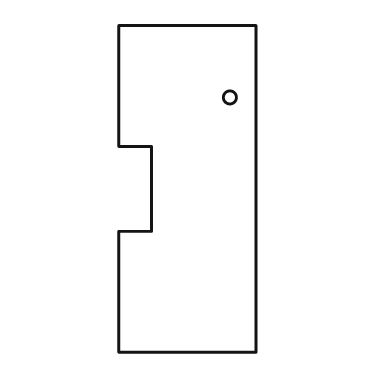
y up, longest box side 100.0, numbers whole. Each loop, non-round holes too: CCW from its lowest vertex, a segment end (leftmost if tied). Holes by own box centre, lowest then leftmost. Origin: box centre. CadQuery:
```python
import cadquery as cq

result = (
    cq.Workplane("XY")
    .moveTo(-21.0, -50.0)
    .lineTo(21.0, -50.0)
    .lineTo(21.0, 50.0)
    .lineTo(-21.0, 50.0)
    .lineTo(-21.0, 13.0)
    .lineTo(-11.0, 13.0)
    .lineTo(-11.0, -13.0)
    .lineTo(-21.0, -13.0)
    .close()
    .moveTo(13.0, 28.0)
    .circle(2.0)
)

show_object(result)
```